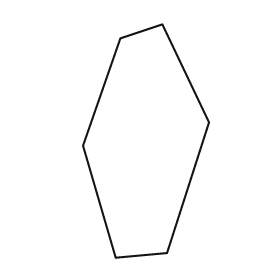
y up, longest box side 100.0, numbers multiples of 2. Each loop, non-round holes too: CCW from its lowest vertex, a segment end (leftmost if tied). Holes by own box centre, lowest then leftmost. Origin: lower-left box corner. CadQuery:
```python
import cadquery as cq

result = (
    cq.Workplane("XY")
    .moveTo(14.0, 0.0)
    .lineTo(36.0, 2.0)
    .lineTo(54.0, 58.0)
    .lineTo(34.0, 100.0)
    .lineTo(16.0, 94.0)
    .lineTo(0.0, 48.0)
    .close()
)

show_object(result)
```